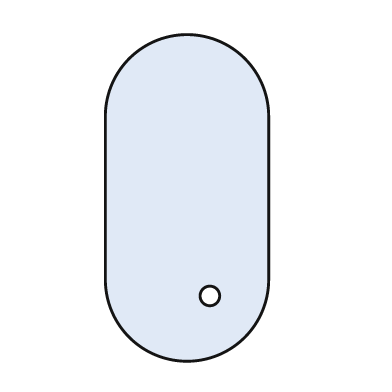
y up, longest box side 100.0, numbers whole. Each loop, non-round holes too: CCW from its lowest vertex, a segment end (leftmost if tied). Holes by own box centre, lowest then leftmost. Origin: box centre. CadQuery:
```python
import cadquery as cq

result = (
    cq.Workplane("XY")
    .moveTo(-25.0, -25.0)
    .threePointArc((0.0, -50.0), (25.0, -25.0))
    .lineTo(25.0, 25.0)
    .threePointArc((0.0, 50.0), (-25.0, 25.0))
    .close()
    .moveTo(7.0, -30.0)
    .circle(3.0)
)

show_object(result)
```